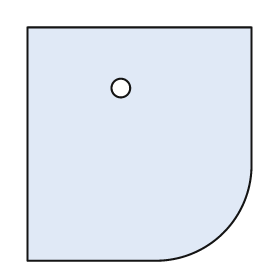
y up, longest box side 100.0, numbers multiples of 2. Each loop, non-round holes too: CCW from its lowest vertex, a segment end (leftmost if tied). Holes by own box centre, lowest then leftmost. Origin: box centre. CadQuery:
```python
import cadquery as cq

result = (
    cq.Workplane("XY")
    .moveTo(-48.0, -50.0)
    .lineTo(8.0, -50.0)
    .threePointArc((36.0, -38.0), (48.0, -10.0))
    .lineTo(48.0, 50.0)
    .lineTo(-48.0, 50.0)
    .close()
    .moveTo(-8.0, 24.0)
    .circle(4.0)
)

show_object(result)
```